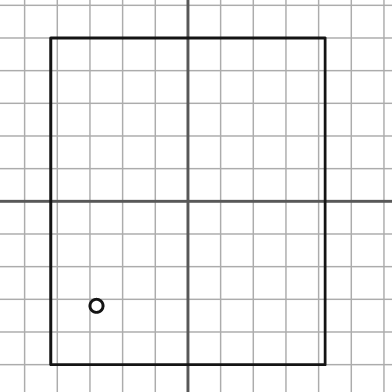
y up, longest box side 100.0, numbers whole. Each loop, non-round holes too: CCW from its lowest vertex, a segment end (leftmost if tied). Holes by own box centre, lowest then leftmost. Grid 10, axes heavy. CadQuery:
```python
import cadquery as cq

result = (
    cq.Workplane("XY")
    .moveTo(-42.0, -50.0)
    .lineTo(42.0, -50.0)
    .lineTo(42.0, 50.0)
    .lineTo(-42.0, 50.0)
    .close()
    .moveTo(-28.0, -32.0)
    .circle(2.0)
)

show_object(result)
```